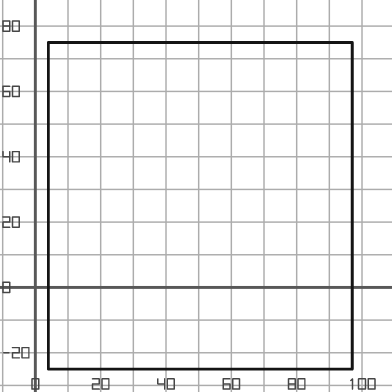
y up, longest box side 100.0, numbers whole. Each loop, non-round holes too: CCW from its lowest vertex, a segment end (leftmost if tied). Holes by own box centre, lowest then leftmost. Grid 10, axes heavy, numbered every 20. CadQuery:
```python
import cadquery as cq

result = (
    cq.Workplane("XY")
    .moveTo(4.0, -25.0)
    .lineTo(97.0, -25.0)
    .lineTo(97.0, 75.0)
    .lineTo(4.0, 75.0)
    .close()
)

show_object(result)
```